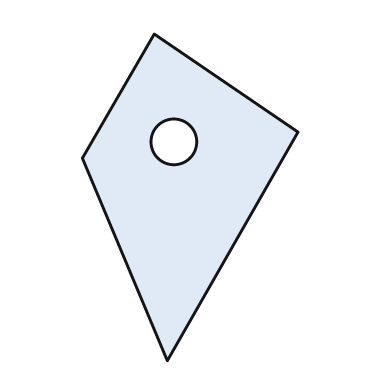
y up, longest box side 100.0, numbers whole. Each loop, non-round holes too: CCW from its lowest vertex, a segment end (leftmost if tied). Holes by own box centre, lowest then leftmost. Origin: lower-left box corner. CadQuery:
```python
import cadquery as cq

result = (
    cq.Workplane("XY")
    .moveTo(26.0, 0.0)
    .lineTo(66.0, 70.0)
    .lineTo(22.0, 100.0)
    .lineTo(0.0, 62.0)
    .close()
    .moveTo(28.0, 67.0)
    .circle(7.0)
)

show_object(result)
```